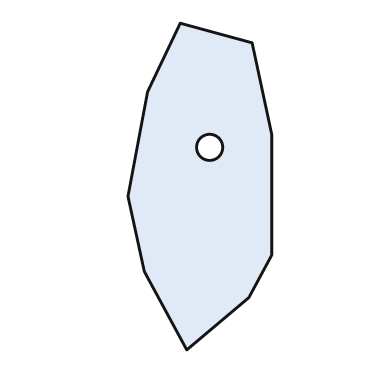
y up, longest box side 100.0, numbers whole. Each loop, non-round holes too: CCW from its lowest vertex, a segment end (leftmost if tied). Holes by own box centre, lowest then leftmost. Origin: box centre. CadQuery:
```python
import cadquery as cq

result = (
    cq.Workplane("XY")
    .moveTo(-4.0, -50.0)
    .lineTo(15.0, -34.0)
    .lineTo(22.0, -21.0)
    .lineTo(22.0, 16.0)
    .lineTo(16.0, 44.0)
    .lineTo(-6.0, 50.0)
    .lineTo(-16.0, 29.0)
    .lineTo(-22.0, -3.0)
    .lineTo(-17.0, -26.0)
    .close()
    .moveTo(3.0, 12.0)
    .circle(4.0)
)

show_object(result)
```